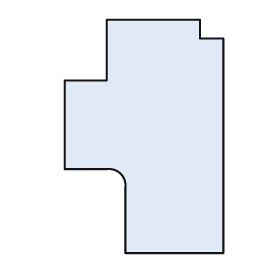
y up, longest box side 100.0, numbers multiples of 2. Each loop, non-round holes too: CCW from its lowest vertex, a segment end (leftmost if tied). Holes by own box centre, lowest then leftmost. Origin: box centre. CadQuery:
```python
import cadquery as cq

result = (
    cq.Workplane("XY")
    .moveTo(-8.0, -50.0)
    .lineTo(34.0, -50.0)
    .lineTo(34.0, 42.0)
    .lineTo(24.0, 42.0)
    .lineTo(24.0, 50.0)
    .lineTo(-16.0, 50.0)
    .lineTo(-16.0, 24.0)
    .lineTo(-34.0, 24.0)
    .lineTo(-34.0, -14.0)
    .lineTo(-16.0, -14.0)
    .threePointArc((-10.0, -16.0), (-8.0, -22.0))
    .close()
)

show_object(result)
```